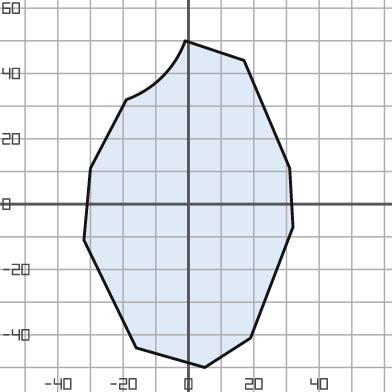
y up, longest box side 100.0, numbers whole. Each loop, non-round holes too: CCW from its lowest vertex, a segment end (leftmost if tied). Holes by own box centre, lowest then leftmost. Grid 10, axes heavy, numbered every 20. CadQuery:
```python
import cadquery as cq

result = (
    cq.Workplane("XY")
    .moveTo(5.0, -50.0)
    .lineTo(19.0, -41.0)
    .lineTo(32.0, -7.0)
    .lineTo(31.0, 11.0)
    .lineTo(17.0, 44.0)
    .lineTo(-1.0, 50.0)
    .threePointArc((-8.0, 39.0), (-19.0, 32.0))
    .lineTo(-30.0, 11.0)
    .lineTo(-32.0, -11.0)
    .lineTo(-16.0, -44.0)
    .close()
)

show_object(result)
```